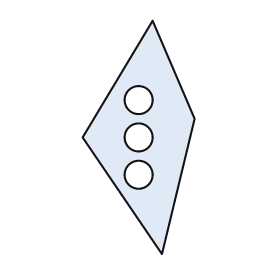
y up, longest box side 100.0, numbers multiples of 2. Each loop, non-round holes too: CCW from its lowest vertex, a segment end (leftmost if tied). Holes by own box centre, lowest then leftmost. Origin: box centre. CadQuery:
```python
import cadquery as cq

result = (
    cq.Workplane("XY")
    .moveTo(10.0, -50.0)
    .lineTo(24.0, 8.0)
    .lineTo(6.0, 50.0)
    .lineTo(-24.0, 0.0)
    .close()
    .moveTo(0.0, -16.0)
    .circle(6.0)
    .moveTo(0.0, 0.0)
    .circle(6.0)
    .moveTo(0.0, 16.0)
    .circle(6.0)
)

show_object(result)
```